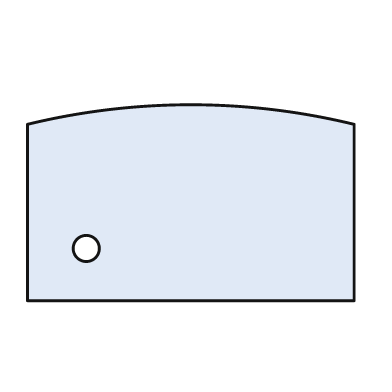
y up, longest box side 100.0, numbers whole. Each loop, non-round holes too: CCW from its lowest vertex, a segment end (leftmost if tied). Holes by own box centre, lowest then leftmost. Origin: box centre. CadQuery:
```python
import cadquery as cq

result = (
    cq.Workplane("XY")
    .moveTo(-50.0, -30.0)
    .lineTo(50.0, -30.0)
    .lineTo(50.0, 24.0)
    .threePointArc((0.0, 30.0), (-50.0, 24.0))
    .close()
    .moveTo(-32.0, -14.0)
    .circle(4.0)
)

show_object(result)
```